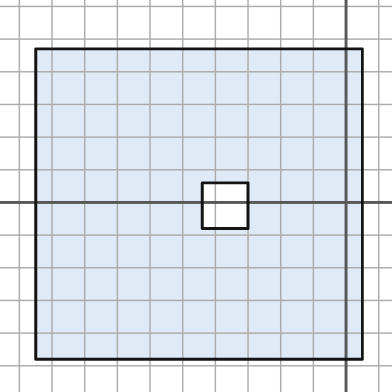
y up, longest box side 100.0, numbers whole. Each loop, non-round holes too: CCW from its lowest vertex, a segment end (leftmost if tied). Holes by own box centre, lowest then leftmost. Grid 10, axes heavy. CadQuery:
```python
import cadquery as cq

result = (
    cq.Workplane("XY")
    .moveTo(-95.0, -48.0)
    .lineTo(5.0, -48.0)
    .lineTo(5.0, 47.0)
    .lineTo(-95.0, 47.0)
    .close()
    .moveTo(-44.0, -8.0)
    .lineTo(-30.0, -8.0)
    .lineTo(-30.0, 6.0)
    .lineTo(-44.0, 6.0)
    .close()
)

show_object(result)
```